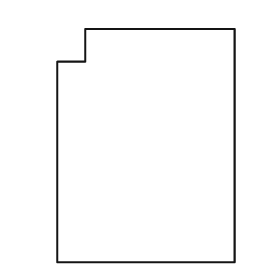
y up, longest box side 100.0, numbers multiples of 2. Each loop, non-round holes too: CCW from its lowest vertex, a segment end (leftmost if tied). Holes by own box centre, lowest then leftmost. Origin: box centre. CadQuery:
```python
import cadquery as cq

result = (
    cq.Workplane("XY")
    .moveTo(-38.0, -50.0)
    .lineTo(38.0, -50.0)
    .lineTo(38.0, 50.0)
    .lineTo(-26.0, 50.0)
    .lineTo(-26.0, 36.0)
    .lineTo(-38.0, 36.0)
    .close()
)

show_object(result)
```